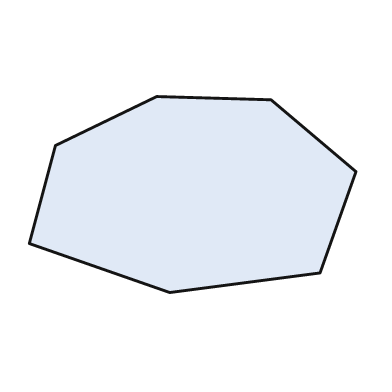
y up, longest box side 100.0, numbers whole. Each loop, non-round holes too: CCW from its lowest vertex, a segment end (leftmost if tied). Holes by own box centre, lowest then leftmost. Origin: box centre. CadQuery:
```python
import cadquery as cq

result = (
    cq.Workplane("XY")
    .moveTo(-7.0, -30.0)
    .lineTo(39.0, -24.0)
    .lineTo(50.0, 7.0)
    .lineTo(24.0, 29.0)
    .lineTo(-11.0, 30.0)
    .lineTo(-42.0, 15.0)
    .lineTo(-50.0, -15.0)
    .close()
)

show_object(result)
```